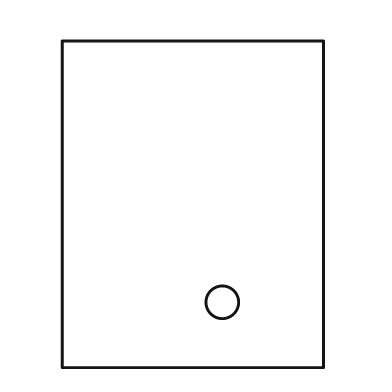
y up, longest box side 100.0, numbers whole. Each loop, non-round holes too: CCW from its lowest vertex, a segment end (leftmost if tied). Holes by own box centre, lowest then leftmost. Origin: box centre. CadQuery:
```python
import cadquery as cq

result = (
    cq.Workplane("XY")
    .moveTo(-40.0, -50.0)
    .lineTo(40.0, -50.0)
    .lineTo(40.0, 50.0)
    .lineTo(-40.0, 50.0)
    .close()
    .moveTo(9.0, -30.0)
    .circle(5.0)
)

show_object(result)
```